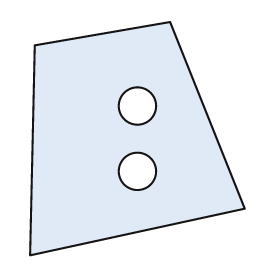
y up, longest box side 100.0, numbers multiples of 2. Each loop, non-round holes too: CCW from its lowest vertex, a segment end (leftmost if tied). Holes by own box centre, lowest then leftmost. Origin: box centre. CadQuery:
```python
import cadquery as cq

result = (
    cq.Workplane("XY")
    .moveTo(-46.0, -50.0)
    .lineTo(46.0, -30.0)
    .lineTo(14.0, 50.0)
    .lineTo(-44.0, 40.0)
    .close()
    .moveTo(0.0, -14.0)
    .circle(8.0)
    .moveTo(0.0, 14.0)
    .circle(8.0)
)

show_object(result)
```